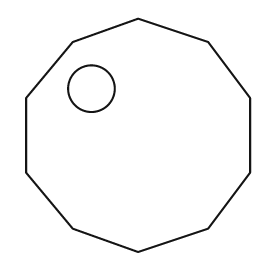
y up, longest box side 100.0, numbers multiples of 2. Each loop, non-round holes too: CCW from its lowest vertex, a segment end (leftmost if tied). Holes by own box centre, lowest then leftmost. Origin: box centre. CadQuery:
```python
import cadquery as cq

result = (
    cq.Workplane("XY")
    .moveTo(0.0, -50.0)
    .lineTo(30.0, -40.0)
    .lineTo(48.0, -16.0)
    .lineTo(48.0, 16.0)
    .lineTo(30.0, 40.0)
    .lineTo(0.0, 50.0)
    .lineTo(-28.0, 40.0)
    .lineTo(-48.0, 16.0)
    .lineTo(-48.0, -16.0)
    .lineTo(-28.0, -40.0)
    .close()
    .moveTo(-20.0, 20.0)
    .circle(10.0)
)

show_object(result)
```